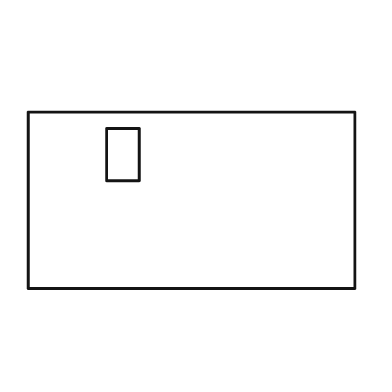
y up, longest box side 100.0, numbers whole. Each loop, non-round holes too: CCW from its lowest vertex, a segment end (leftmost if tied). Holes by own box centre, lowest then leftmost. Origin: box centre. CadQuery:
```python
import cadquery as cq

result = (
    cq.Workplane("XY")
    .moveTo(-50.0, -27.0)
    .lineTo(50.0, -27.0)
    .lineTo(50.0, 27.0)
    .lineTo(-50.0, 27.0)
    .close()
    .moveTo(-26.0, 6.0)
    .lineTo(-16.0, 6.0)
    .lineTo(-16.0, 22.0)
    .lineTo(-26.0, 22.0)
    .close()
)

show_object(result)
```